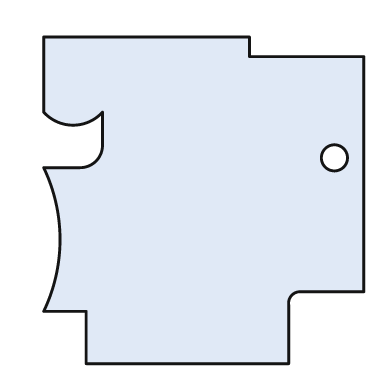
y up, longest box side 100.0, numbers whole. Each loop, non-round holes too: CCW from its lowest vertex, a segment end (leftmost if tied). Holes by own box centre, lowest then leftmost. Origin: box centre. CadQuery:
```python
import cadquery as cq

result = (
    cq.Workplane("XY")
    .moveTo(-36.0, -50.0)
    .lineTo(26.0, -50.0)
    .lineTo(26.0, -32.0)
    .threePointArc((27.0, -29.0), (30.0, -28.0))
    .lineTo(49.0, -28.0)
    .lineTo(49.0, 44.0)
    .lineTo(14.0, 44.0)
    .lineTo(14.0, 50.0)
    .lineTo(-49.0, 50.0)
    .lineTo(-49.0, 27.0)
    .threePointArc((-40.0, 23.0), (-31.0, 27.0))
    .lineTo(-31.0, 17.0)
    .threePointArc((-33.0, 12.0), (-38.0, 10.0))
    .lineTo(-49.0, 10.0)
    .threePointArc((-44.0, -12.0), (-49.0, -34.0))
    .lineTo(-36.0, -34.0)
    .close()
    .moveTo(40.0, 13.0)
    .circle(4.0)
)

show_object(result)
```